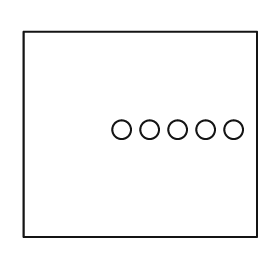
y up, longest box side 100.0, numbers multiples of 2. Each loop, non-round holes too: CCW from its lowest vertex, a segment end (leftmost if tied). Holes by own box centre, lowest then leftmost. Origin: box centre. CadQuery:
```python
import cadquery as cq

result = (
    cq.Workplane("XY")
    .moveTo(-50.0, -44.0)
    .lineTo(50.0, -44.0)
    .lineTo(50.0, 44.0)
    .lineTo(-50.0, 44.0)
    .close()
    .moveTo(-8.0, 2.0)
    .circle(4.0)
    .moveTo(4.0, 2.0)
    .circle(4.0)
    .moveTo(16.0, 2.0)
    .circle(4.0)
    .moveTo(28.0, 2.0)
    .circle(4.0)
    .moveTo(40.0, 2.0)
    .circle(4.0)
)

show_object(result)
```